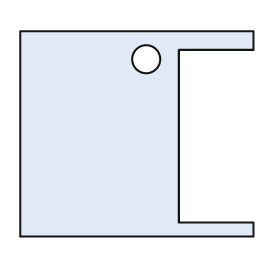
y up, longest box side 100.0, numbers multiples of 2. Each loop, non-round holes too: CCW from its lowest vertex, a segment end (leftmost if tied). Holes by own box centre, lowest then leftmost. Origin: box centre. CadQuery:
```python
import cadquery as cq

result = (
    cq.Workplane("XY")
    .moveTo(-50.0, -44.0)
    .lineTo(50.0, -44.0)
    .lineTo(50.0, -38.0)
    .lineTo(18.0, -38.0)
    .lineTo(18.0, 36.0)
    .lineTo(50.0, 36.0)
    .lineTo(50.0, 44.0)
    .lineTo(-50.0, 44.0)
    .close()
    .moveTo(4.0, 32.0)
    .circle(6.0)
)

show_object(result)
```